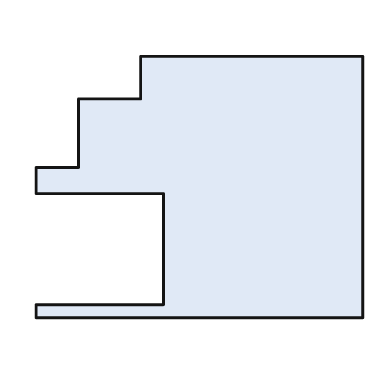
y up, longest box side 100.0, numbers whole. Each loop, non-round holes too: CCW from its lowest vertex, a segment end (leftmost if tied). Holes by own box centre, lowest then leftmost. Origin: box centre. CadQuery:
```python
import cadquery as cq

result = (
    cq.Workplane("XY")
    .moveTo(-50.0, -40.0)
    .lineTo(50.0, -40.0)
    .lineTo(50.0, 40.0)
    .lineTo(-18.0, 40.0)
    .lineTo(-18.0, 27.0)
    .lineTo(-37.0, 27.0)
    .lineTo(-37.0, 6.0)
    .lineTo(-50.0, 6.0)
    .lineTo(-50.0, -2.0)
    .lineTo(-11.0, -2.0)
    .lineTo(-11.0, -36.0)
    .lineTo(-50.0, -36.0)
    .close()
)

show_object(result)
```